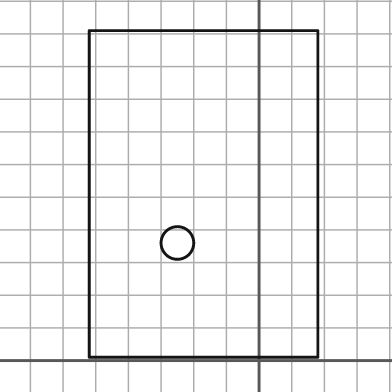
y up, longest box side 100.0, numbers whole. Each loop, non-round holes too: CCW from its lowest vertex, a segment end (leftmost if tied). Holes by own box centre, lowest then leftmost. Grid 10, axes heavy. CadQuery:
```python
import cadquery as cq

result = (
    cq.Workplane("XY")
    .moveTo(-52.0, 1.0)
    .lineTo(18.0, 1.0)
    .lineTo(18.0, 101.0)
    .lineTo(-52.0, 101.0)
    .close()
    .moveTo(-25.0, 36.0)
    .circle(5.0)
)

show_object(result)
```